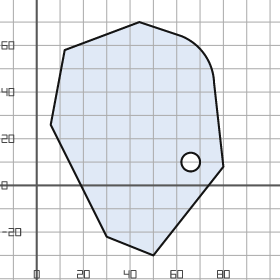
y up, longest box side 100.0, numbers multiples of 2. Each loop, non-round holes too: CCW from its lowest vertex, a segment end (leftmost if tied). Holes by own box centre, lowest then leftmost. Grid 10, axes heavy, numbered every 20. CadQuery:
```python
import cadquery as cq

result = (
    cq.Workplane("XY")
    .moveTo(50.0, -30.0)
    .lineTo(80.0, 8.0)
    .lineTo(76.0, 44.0)
    .threePointArc((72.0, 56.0), (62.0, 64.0))
    .lineTo(44.0, 70.0)
    .lineTo(12.0, 58.0)
    .lineTo(6.0, 26.0)
    .lineTo(30.0, -22.0)
    .close()
    .moveTo(66.0, 10.0)
    .circle(4.0)
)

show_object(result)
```